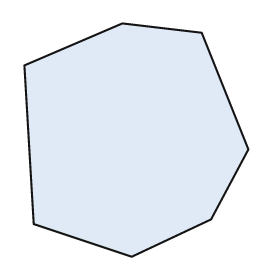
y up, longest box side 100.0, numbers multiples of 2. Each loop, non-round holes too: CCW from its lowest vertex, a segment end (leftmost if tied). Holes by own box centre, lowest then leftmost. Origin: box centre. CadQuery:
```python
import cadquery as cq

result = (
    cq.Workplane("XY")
    .moveTo(-2.0, -50.0)
    .lineTo(32.0, -34.0)
    .lineTo(48.0, -4.0)
    .lineTo(28.0, 46.0)
    .lineTo(-6.0, 50.0)
    .lineTo(-48.0, 32.0)
    .lineTo(-44.0, -36.0)
    .close()
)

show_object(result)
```